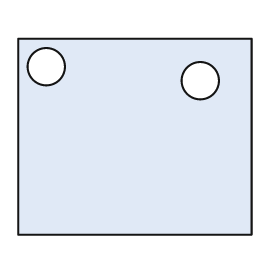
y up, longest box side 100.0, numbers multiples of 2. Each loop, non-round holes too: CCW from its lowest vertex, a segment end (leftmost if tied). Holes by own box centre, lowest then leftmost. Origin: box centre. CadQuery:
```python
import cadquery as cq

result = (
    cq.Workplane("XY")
    .moveTo(-50.0, -42.0)
    .lineTo(50.0, -42.0)
    .lineTo(50.0, 42.0)
    .lineTo(-50.0, 42.0)
    .close()
    .moveTo(28.0, 24.0)
    .circle(8.0)
    .moveTo(-38.0, 30.0)
    .circle(8.0)
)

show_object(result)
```